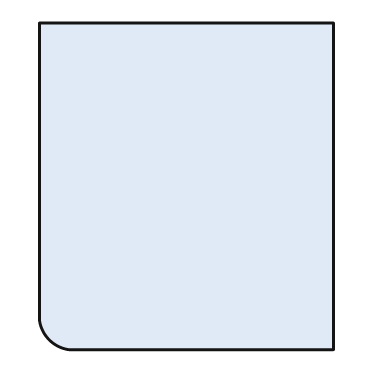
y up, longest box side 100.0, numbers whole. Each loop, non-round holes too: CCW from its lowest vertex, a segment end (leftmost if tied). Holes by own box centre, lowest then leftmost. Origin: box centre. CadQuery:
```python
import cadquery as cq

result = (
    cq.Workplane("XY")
    .moveTo(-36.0, -50.0)
    .lineTo(45.0, -50.0)
    .lineTo(45.0, 50.0)
    .lineTo(-45.0, 50.0)
    .lineTo(-45.0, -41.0)
    .threePointArc((-42.0, -47.0), (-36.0, -50.0))
    .close()
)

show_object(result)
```